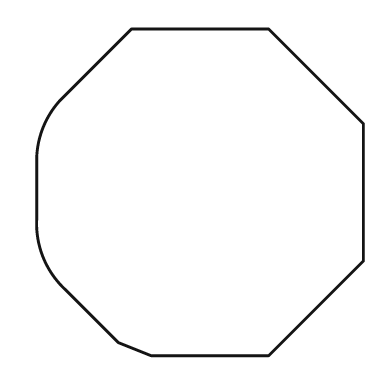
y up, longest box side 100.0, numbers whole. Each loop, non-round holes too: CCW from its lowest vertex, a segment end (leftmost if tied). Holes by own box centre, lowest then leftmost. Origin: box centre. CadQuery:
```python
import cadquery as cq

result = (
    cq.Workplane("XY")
    .moveTo(-15.0, -50.0)
    .lineTo(21.0, -50.0)
    .lineTo(50.0, -21.0)
    .lineTo(50.0, 21.0)
    .lineTo(21.0, 50.0)
    .lineTo(-21.0, 50.0)
    .lineTo(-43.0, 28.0)
    .threePointArc((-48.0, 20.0), (-50.0, 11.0))
    .lineTo(-50.0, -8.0)
    .threePointArc((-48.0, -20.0), (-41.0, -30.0))
    .lineTo(-25.0, -46.0)
    .close()
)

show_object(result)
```